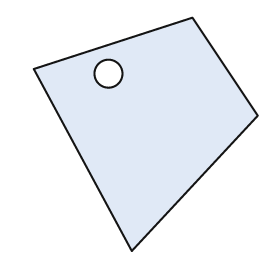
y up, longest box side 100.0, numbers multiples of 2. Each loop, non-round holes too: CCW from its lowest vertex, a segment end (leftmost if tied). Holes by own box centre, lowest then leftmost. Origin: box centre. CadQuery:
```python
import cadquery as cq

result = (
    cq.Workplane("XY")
    .moveTo(-6.0, -50.0)
    .lineTo(48.0, 8.0)
    .lineTo(20.0, 50.0)
    .lineTo(-48.0, 28.0)
    .close()
    .moveTo(-16.0, 26.0)
    .circle(6.0)
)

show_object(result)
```